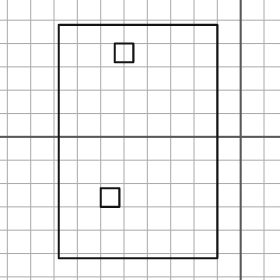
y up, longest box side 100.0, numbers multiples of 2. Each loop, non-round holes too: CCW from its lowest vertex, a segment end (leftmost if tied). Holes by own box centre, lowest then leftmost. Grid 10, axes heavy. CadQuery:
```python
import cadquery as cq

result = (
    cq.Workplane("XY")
    .moveTo(-78.0, -52.0)
    .lineTo(-10.0, -52.0)
    .lineTo(-10.0, 48.0)
    .lineTo(-78.0, 48.0)
    .close()
    .moveTo(-60.0, -30.0)
    .lineTo(-52.0, -30.0)
    .lineTo(-52.0, -22.0)
    .lineTo(-60.0, -22.0)
    .close()
    .moveTo(-54.0, 32.0)
    .lineTo(-46.0, 32.0)
    .lineTo(-46.0, 40.0)
    .lineTo(-54.0, 40.0)
    .close()
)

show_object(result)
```